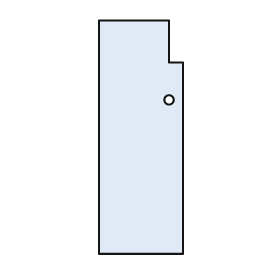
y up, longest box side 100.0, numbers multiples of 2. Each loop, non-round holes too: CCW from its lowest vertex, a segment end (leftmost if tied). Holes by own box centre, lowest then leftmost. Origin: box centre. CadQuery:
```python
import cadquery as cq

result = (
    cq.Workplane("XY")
    .moveTo(-18.0, -50.0)
    .lineTo(18.0, -50.0)
    .lineTo(18.0, 32.0)
    .lineTo(12.0, 32.0)
    .lineTo(12.0, 50.0)
    .lineTo(-18.0, 50.0)
    .close()
    .moveTo(12.0, 16.0)
    .circle(2.0)
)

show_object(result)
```